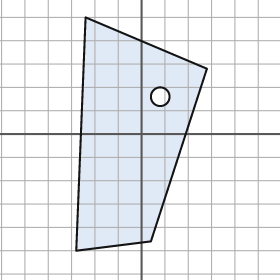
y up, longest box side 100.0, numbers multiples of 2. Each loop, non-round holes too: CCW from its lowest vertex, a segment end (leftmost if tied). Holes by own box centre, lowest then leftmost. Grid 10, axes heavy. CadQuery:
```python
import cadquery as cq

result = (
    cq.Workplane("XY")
    .moveTo(-28.0, -50.0)
    .lineTo(4.0, -46.0)
    .lineTo(28.0, 28.0)
    .lineTo(-24.0, 50.0)
    .close()
    .moveTo(8.0, 16.0)
    .circle(4.0)
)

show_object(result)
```